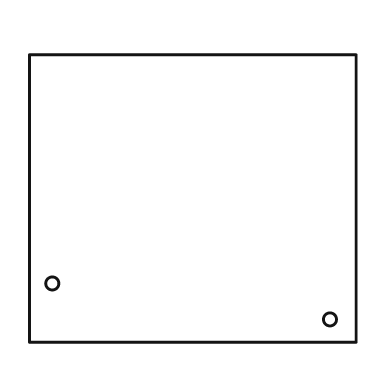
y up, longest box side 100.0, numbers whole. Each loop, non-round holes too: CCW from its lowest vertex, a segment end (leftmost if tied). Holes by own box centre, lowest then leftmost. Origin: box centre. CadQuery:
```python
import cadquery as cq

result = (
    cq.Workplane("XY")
    .moveTo(-50.0, -44.0)
    .lineTo(50.0, -44.0)
    .lineTo(50.0, 44.0)
    .lineTo(-50.0, 44.0)
    .close()
    .moveTo(42.0, -37.0)
    .circle(2.0)
    .moveTo(-43.0, -26.0)
    .circle(2.0)
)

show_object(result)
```